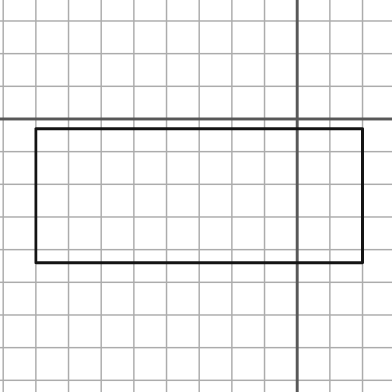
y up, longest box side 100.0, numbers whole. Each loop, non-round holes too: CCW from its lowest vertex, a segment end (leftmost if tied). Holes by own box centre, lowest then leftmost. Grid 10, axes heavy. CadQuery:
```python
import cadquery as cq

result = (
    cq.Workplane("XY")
    .moveTo(-80.0, -44.0)
    .lineTo(20.0, -44.0)
    .lineTo(20.0, -3.0)
    .lineTo(-80.0, -3.0)
    .close()
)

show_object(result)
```